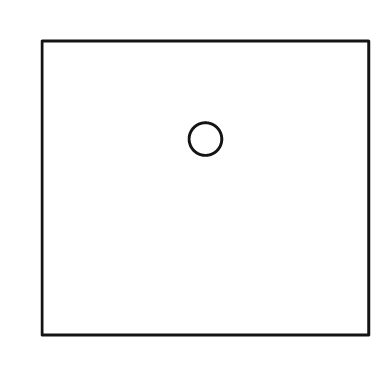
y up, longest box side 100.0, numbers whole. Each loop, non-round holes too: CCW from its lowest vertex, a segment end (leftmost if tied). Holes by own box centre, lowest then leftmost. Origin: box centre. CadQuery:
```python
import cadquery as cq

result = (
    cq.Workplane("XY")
    .moveTo(-50.0, -45.0)
    .lineTo(50.0, -45.0)
    .lineTo(50.0, 45.0)
    .lineTo(-50.0, 45.0)
    .close()
    .moveTo(0.0, 15.0)
    .circle(5.0)
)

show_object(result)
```